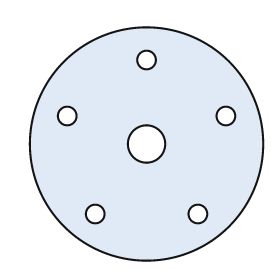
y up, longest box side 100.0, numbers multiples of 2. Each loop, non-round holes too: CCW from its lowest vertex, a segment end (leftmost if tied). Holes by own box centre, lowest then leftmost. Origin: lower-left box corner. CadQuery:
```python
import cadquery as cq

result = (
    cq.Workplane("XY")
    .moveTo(50.0, 50.0)
    .circle(50.0)
    .moveTo(28.0, 20.0)
    .circle(4.0)
    .moveTo(72.0, 20.0)
    .circle(4.0)
    .moveTo(50.0, 50.0)
    .circle(8.0)
    .moveTo(16.0, 62.0)
    .circle(4.0)
    .moveTo(84.0, 62.0)
    .circle(4.0)
    .moveTo(50.0, 86.0)
    .circle(4.0)
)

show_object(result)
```